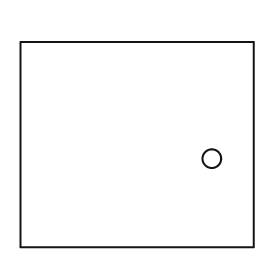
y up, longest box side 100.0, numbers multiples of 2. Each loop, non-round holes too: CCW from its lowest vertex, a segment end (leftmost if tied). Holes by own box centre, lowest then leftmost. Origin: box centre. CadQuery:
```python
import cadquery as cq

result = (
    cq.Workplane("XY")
    .moveTo(-50.0, -44.0)
    .lineTo(50.0, -44.0)
    .lineTo(50.0, 44.0)
    .lineTo(-50.0, 44.0)
    .close()
    .moveTo(32.0, -6.0)
    .circle(4.0)
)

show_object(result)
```